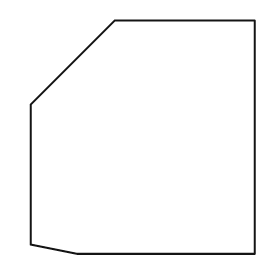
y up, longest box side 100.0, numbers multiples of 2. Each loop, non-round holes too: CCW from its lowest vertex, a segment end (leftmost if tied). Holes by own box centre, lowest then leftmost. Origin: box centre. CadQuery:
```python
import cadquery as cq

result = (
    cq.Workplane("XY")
    .moveTo(-28.0, -50.0)
    .lineTo(48.0, -50.0)
    .lineTo(48.0, 50.0)
    .lineTo(-12.0, 50.0)
    .lineTo(-48.0, 14.0)
    .lineTo(-48.0, -46.0)
    .close()
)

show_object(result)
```